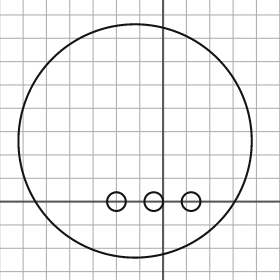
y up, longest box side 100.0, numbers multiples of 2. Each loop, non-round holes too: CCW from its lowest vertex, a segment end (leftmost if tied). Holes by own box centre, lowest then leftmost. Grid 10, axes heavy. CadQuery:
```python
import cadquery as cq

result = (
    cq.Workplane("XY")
    .moveTo(-12.0, 26.0)
    .circle(50.0)
    .moveTo(-20.0, 0.0)
    .circle(4.0)
    .moveTo(-4.0, 0.0)
    .circle(4.0)
    .moveTo(12.0, 0.0)
    .circle(4.0)
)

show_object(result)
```